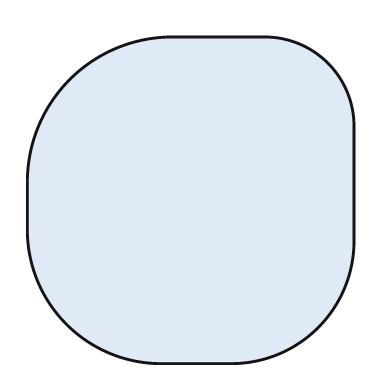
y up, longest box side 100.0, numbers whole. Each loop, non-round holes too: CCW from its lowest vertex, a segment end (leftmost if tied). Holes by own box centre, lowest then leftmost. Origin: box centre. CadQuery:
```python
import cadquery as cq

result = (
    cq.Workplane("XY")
    .moveTo(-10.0, -50.0)
    .lineTo(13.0, -50.0)
    .threePointArc((39.0, -39.0), (50.0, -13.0))
    .lineTo(50.0, 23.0)
    .threePointArc((42.0, 42.0), (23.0, 50.0))
    .lineTo(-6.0, 50.0)
    .threePointArc((-37.0, 37.0), (-50.0, 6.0))
    .lineTo(-50.0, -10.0)
    .threePointArc((-38.0, -38.0), (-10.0, -50.0))
    .close()
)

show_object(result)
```